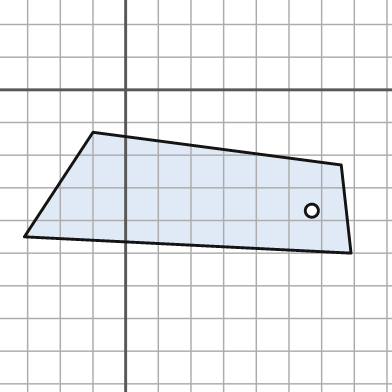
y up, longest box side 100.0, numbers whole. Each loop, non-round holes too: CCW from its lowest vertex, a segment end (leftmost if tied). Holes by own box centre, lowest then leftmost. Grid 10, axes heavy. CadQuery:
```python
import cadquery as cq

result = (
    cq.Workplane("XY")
    .moveTo(69.0, -50.0)
    .lineTo(66.0, -23.0)
    .lineTo(-10.0, -13.0)
    .lineTo(-31.0, -45.0)
    .close()
    .moveTo(57.0, -37.0)
    .circle(2.0)
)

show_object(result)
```